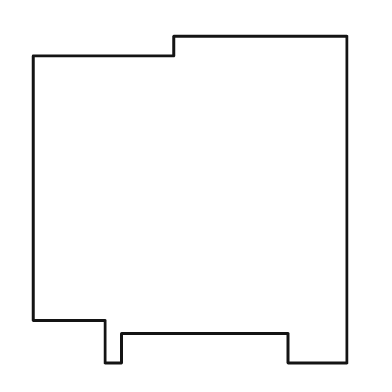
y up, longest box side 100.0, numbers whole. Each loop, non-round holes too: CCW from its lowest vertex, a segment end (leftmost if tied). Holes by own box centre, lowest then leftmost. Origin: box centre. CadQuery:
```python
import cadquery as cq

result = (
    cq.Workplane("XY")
    .moveTo(-26.0, -50.0)
    .lineTo(-21.0, -50.0)
    .lineTo(-21.0, -41.0)
    .lineTo(30.0, -41.0)
    .lineTo(30.0, -50.0)
    .lineTo(48.0, -50.0)
    .lineTo(48.0, 50.0)
    .lineTo(-5.0, 50.0)
    .lineTo(-5.0, 44.0)
    .lineTo(-48.0, 44.0)
    .lineTo(-48.0, -37.0)
    .lineTo(-26.0, -37.0)
    .close()
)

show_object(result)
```